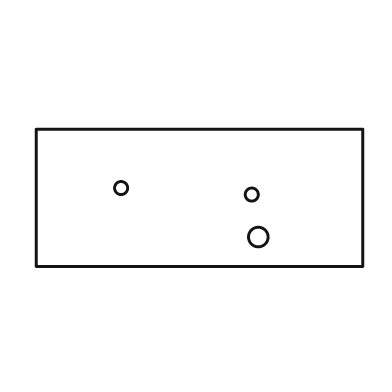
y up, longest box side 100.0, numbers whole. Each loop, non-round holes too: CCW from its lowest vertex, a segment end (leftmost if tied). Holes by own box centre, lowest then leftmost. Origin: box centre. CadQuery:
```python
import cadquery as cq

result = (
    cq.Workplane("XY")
    .moveTo(-50.0, -21.0)
    .lineTo(50.0, -21.0)
    .lineTo(50.0, 21.0)
    .lineTo(-50.0, 21.0)
    .close()
    .moveTo(18.0, -12.0)
    .circle(3.0)
    .moveTo(16.0, 1.0)
    .circle(2.0)
    .moveTo(-24.0, 3.0)
    .circle(2.0)
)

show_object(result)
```